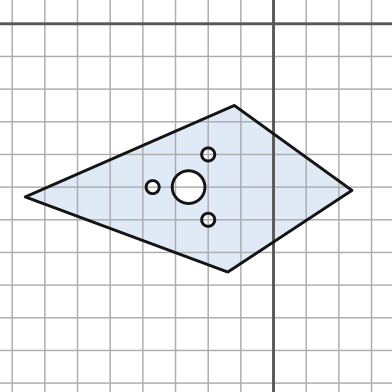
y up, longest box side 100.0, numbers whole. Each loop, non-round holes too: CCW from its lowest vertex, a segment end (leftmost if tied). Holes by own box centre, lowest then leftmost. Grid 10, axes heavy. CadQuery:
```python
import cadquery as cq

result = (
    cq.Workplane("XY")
    .moveTo(-14.0, -76.0)
    .lineTo(24.0, -51.0)
    .lineTo(-12.0, -25.0)
    .lineTo(-76.0, -53.0)
    .close()
    .moveTo(-20.0, -60.0)
    .circle(2.0)
    .moveTo(-37.0, -50.0)
    .circle(2.0)
    .moveTo(-26.0, -50.0)
    .circle(5.0)
    .moveTo(-20.0, -40.0)
    .circle(2.0)
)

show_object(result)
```